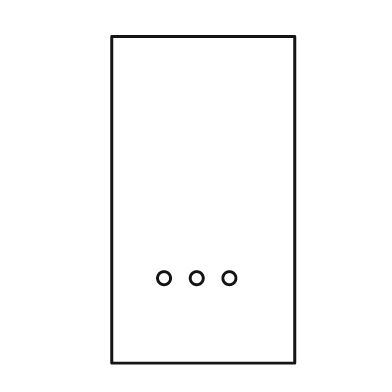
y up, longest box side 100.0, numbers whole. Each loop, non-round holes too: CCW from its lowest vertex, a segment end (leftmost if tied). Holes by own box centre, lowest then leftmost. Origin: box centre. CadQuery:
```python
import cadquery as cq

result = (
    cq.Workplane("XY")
    .moveTo(-28.0, -50.0)
    .lineTo(28.0, -50.0)
    .lineTo(28.0, 50.0)
    .lineTo(-28.0, 50.0)
    .close()
    .moveTo(-12.0, -24.0)
    .circle(2.0)
    .moveTo(-2.0, -24.0)
    .circle(2.0)
    .moveTo(8.0, -24.0)
    .circle(2.0)
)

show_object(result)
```